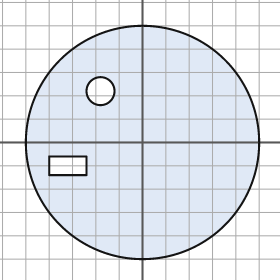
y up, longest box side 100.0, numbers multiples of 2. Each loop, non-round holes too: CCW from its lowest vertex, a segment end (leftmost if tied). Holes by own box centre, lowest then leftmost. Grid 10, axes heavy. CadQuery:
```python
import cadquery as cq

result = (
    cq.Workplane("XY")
    .moveTo(0.0, 0.0)
    .circle(50.0)
    .moveTo(-40.0, -14.0)
    .lineTo(-24.0, -14.0)
    .lineTo(-24.0, -6.0)
    .lineTo(-40.0, -6.0)
    .close()
    .moveTo(-18.0, 22.0)
    .circle(6.0)
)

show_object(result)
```